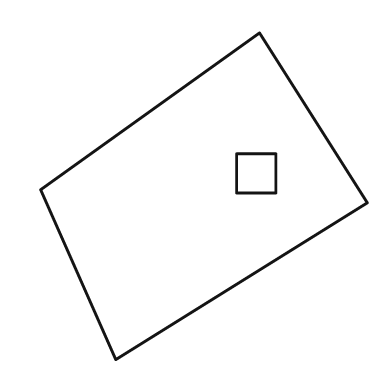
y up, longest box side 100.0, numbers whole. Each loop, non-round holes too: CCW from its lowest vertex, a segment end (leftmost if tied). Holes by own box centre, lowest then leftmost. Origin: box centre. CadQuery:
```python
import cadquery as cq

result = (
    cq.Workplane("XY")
    .moveTo(-27.0, -50.0)
    .lineTo(50.0, -2.0)
    .lineTo(17.0, 50.0)
    .lineTo(-50.0, 2.0)
    .close()
    .moveTo(10.0, 1.0)
    .lineTo(22.0, 1.0)
    .lineTo(22.0, 13.0)
    .lineTo(10.0, 13.0)
    .close()
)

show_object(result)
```